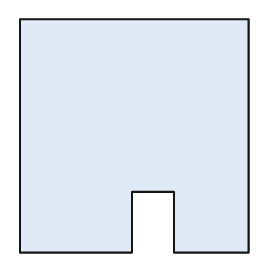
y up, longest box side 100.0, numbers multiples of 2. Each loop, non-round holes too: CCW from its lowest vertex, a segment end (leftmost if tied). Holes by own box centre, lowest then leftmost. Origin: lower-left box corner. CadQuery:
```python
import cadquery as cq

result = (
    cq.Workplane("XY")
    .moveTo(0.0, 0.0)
    .lineTo(48.0, 0.0)
    .lineTo(48.0, 26.0)
    .lineTo(66.0, 26.0)
    .lineTo(66.0, 0.0)
    .lineTo(98.0, 0.0)
    .lineTo(98.0, 100.0)
    .lineTo(0.0, 100.0)
    .close()
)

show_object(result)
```